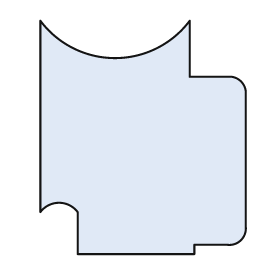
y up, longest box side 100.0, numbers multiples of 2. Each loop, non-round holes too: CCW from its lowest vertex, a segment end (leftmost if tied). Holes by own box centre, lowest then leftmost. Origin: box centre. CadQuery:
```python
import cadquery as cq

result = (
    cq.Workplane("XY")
    .moveTo(-28.0, -50.0)
    .lineTo(22.0, -50.0)
    .lineTo(22.0, -46.0)
    .lineTo(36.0, -46.0)
    .threePointArc((42.0, -44.0), (44.0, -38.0))
    .lineTo(44.0, 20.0)
    .threePointArc((42.0, 24.0), (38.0, 26.0))
    .lineTo(20.0, 26.0)
    .lineTo(20.0, 50.0)
    .threePointArc((-12.0, 34.0), (-44.0, 50.0))
    .lineTo(-44.0, -32.0)
    .threePointArc((-36.0, -28.0), (-28.0, -32.0))
    .close()
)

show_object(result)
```